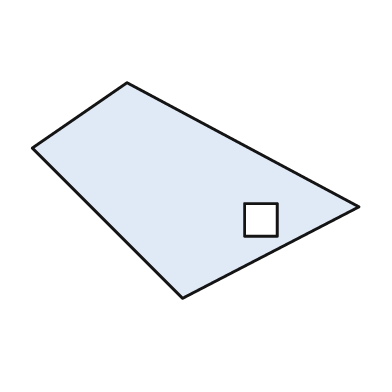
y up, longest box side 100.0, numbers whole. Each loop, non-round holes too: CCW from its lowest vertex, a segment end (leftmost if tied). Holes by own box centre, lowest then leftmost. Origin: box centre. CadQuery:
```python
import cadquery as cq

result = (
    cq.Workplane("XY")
    .moveTo(-4.0, -33.0)
    .lineTo(50.0, -5.0)
    .lineTo(-21.0, 33.0)
    .lineTo(-50.0, 13.0)
    .close()
    .moveTo(15.0, -14.0)
    .lineTo(25.0, -14.0)
    .lineTo(25.0, -4.0)
    .lineTo(15.0, -4.0)
    .close()
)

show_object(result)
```